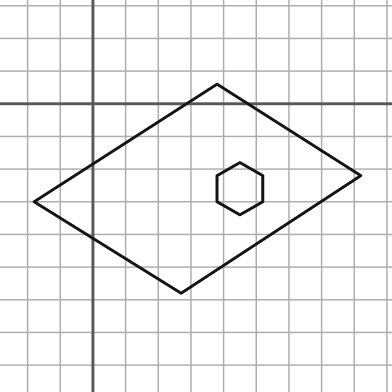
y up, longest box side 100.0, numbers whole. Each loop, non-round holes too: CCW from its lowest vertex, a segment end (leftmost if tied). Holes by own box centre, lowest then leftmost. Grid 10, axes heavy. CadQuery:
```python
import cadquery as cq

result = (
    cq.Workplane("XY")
    .moveTo(27.0, -58.0)
    .lineTo(82.0, -22.0)
    .lineTo(38.0, 6.0)
    .lineTo(-18.0, -30.0)
    .close()
    .moveTo(45.0, -34.0)
    .lineTo(52.0, -30.0)
    .lineTo(52.0, -22.0)
    .lineTo(45.0, -18.0)
    .lineTo(38.0, -22.0)
    .lineTo(38.0, -30.0)
    .close()
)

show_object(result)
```